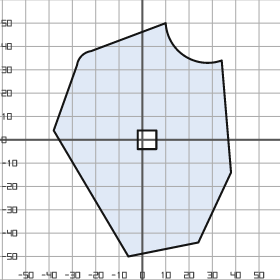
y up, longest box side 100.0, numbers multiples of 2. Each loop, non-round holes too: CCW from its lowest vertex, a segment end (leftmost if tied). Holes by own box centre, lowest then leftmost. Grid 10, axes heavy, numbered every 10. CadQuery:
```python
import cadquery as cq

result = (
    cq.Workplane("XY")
    .moveTo(-6.0, -50.0)
    .lineTo(24.0, -44.0)
    .lineTo(38.0, -14.0)
    .lineTo(34.0, 34.0)
    .threePointArc((18.0, 36.0), (10.0, 50.0))
    .lineTo(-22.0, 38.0)
    .threePointArc((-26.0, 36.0), (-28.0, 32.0))
    .lineTo(-38.0, 4.0)
    .close()
    .moveTo(-2.0, -4.0)
    .lineTo(6.0, -4.0)
    .lineTo(6.0, 4.0)
    .lineTo(-2.0, 4.0)
    .close()
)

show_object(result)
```